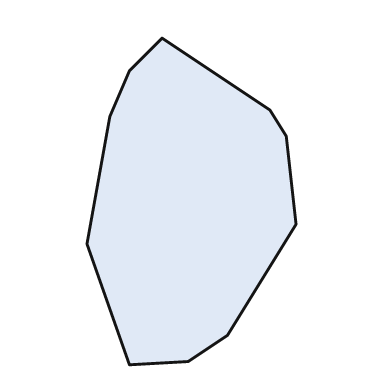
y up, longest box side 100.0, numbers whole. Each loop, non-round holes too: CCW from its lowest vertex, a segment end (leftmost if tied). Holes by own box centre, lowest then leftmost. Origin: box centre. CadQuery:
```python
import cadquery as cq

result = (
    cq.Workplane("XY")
    .moveTo(-19.0, -50.0)
    .lineTo(-1.0, -49.0)
    .lineTo(11.0, -41.0)
    .lineTo(32.0, -7.0)
    .lineTo(29.0, 20.0)
    .lineTo(24.0, 28.0)
    .lineTo(-9.0, 50.0)
    .lineTo(-19.0, 40.0)
    .lineTo(-25.0, 26.0)
    .lineTo(-32.0, -13.0)
    .close()
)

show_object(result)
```